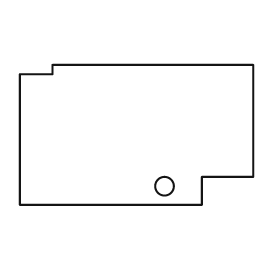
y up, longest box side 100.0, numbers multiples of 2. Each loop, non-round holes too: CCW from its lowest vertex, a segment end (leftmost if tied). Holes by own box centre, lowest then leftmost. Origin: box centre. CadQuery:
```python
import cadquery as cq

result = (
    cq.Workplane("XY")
    .moveTo(-50.0, -30.0)
    .lineTo(28.0, -30.0)
    .lineTo(28.0, -18.0)
    .lineTo(50.0, -18.0)
    .lineTo(50.0, 30.0)
    .lineTo(-36.0, 30.0)
    .lineTo(-36.0, 26.0)
    .lineTo(-50.0, 26.0)
    .close()
    .moveTo(12.0, -22.0)
    .circle(4.0)
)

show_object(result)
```